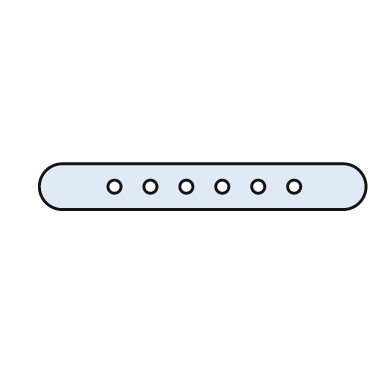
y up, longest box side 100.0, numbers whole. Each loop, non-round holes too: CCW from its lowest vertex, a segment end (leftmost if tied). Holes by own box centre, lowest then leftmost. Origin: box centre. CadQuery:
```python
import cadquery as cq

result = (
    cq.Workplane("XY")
    .moveTo(-43.0, -7.0)
    .lineTo(43.0, -7.0)
    .threePointArc((50.0, 0.0), (43.0, 7.0))
    .lineTo(-43.0, 7.0)
    .threePointArc((-50.0, 0.0), (-43.0, -7.0))
    .close()
    .moveTo(-27.0, 0.0)
    .circle(2.0)
    .moveTo(-16.0, 0.0)
    .circle(2.0)
    .moveTo(-5.0, 0.0)
    .circle(2.0)
    .moveTo(6.0, 0.0)
    .circle(2.0)
    .moveTo(17.0, 0.0)
    .circle(2.0)
    .moveTo(28.0, 0.0)
    .circle(2.0)
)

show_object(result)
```